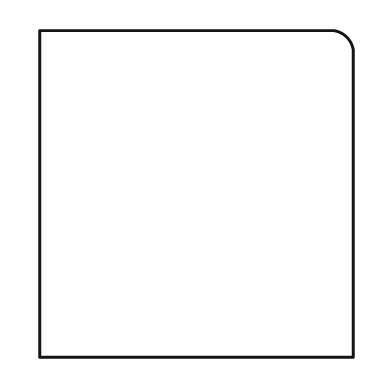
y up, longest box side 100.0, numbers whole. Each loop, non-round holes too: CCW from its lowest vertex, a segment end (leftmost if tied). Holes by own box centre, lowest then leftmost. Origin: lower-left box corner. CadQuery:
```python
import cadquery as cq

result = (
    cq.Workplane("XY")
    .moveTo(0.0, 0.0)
    .lineTo(96.0, 0.0)
    .lineTo(96.0, 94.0)
    .threePointArc((94.0, 98.0), (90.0, 100.0))
    .lineTo(0.0, 100.0)
    .close()
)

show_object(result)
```